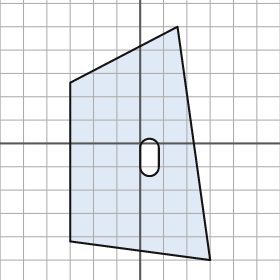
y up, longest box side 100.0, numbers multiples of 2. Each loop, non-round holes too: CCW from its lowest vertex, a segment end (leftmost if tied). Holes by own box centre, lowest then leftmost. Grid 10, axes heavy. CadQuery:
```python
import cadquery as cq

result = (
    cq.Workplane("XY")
    .moveTo(30.0, -50.0)
    .lineTo(16.0, 50.0)
    .lineTo(-30.0, 26.0)
    .lineTo(-30.0, -42.0)
    .close()
    .moveTo(0.0, -10.0)
    .threePointArc((4.0, -14.0), (8.0, -10.0))
    .lineTo(8.0, -2.0)
    .threePointArc((4.0, 2.0), (0.0, -2.0))
    .close()
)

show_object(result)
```